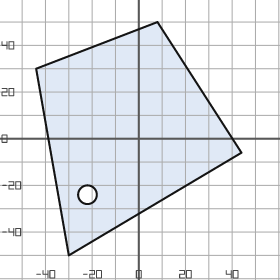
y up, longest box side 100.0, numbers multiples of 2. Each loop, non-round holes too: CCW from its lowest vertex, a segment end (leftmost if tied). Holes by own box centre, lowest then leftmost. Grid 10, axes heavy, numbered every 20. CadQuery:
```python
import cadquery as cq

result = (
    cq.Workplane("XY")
    .moveTo(-30.0, -50.0)
    .lineTo(44.0, -6.0)
    .lineTo(8.0, 50.0)
    .lineTo(-44.0, 30.0)
    .close()
    .moveTo(-22.0, -24.0)
    .circle(4.0)
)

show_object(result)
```